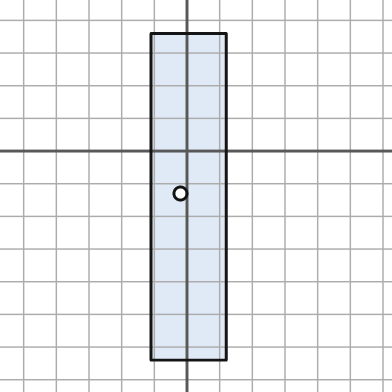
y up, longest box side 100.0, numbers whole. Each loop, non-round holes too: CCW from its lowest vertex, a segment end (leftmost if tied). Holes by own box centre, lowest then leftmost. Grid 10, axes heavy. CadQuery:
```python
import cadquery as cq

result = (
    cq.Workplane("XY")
    .moveTo(-11.0, -64.0)
    .lineTo(12.0, -64.0)
    .lineTo(12.0, 36.0)
    .lineTo(-11.0, 36.0)
    .close()
    .moveTo(-2.0, -13.0)
    .circle(2.0)
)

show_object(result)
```